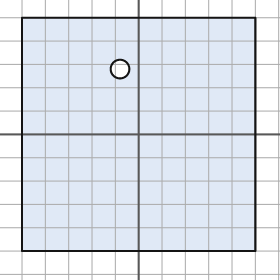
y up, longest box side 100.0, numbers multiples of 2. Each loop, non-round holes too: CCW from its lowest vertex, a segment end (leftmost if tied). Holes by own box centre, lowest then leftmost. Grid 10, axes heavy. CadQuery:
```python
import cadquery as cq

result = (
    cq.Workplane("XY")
    .moveTo(-50.0, -50.0)
    .lineTo(50.0, -50.0)
    .lineTo(50.0, 50.0)
    .lineTo(-50.0, 50.0)
    .close()
    .moveTo(-8.0, 28.0)
    .circle(4.0)
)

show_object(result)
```